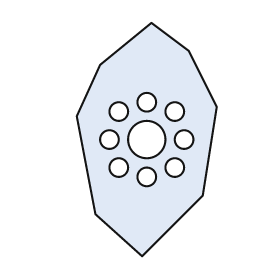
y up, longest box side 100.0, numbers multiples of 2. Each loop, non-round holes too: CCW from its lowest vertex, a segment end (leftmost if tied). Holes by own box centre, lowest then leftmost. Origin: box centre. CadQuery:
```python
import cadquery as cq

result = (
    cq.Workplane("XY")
    .moveTo(-2.0, -50.0)
    .lineTo(24.0, -24.0)
    .lineTo(30.0, 14.0)
    .lineTo(18.0, 38.0)
    .lineTo(2.0, 50.0)
    .lineTo(-20.0, 32.0)
    .lineTo(-30.0, 10.0)
    .lineTo(-22.0, -32.0)
    .close()
    .moveTo(0.0, -16.0)
    .circle(4.0)
    .moveTo(-12.0, -12.0)
    .circle(4.0)
    .moveTo(12.0, -12.0)
    .circle(4.0)
    .moveTo(-16.0, 0.0)
    .circle(4.0)
    .moveTo(0.0, 0.0)
    .circle(8.0)
    .moveTo(16.0, 0.0)
    .circle(4.0)
    .moveTo(-12.0, 12.0)
    .circle(4.0)
    .moveTo(12.0, 12.0)
    .circle(4.0)
    .moveTo(0.0, 16.0)
    .circle(4.0)
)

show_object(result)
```